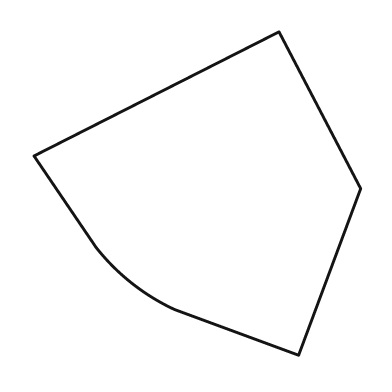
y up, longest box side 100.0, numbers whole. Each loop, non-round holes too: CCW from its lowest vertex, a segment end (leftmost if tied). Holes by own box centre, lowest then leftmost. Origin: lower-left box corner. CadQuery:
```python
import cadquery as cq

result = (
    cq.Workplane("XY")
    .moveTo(81.0, 0.0)
    .lineTo(100.0, 51.0)
    .lineTo(75.0, 99.0)
    .lineTo(0.0, 61.0)
    .lineTo(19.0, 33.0)
    .threePointArc((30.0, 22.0), (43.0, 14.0))
    .close()
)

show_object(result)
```